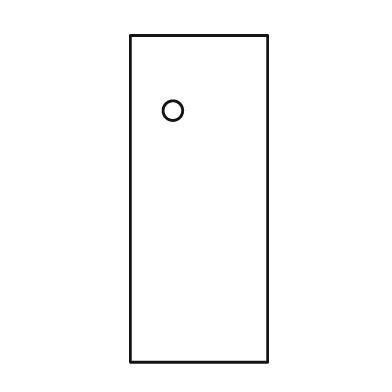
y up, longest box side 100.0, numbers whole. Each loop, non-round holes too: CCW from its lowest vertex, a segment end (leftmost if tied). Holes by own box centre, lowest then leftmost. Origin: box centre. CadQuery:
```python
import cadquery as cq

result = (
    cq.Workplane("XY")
    .moveTo(-21.0, -50.0)
    .lineTo(21.0, -50.0)
    .lineTo(21.0, 50.0)
    .lineTo(-21.0, 50.0)
    .close()
    .moveTo(-8.0, 27.0)
    .circle(3.0)
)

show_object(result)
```